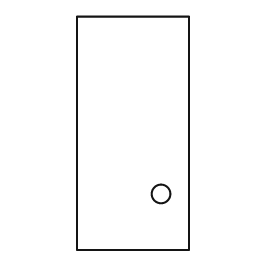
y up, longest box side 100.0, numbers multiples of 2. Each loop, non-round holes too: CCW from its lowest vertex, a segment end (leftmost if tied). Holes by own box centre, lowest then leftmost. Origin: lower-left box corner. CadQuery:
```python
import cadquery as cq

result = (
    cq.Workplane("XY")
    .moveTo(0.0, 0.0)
    .lineTo(48.0, 0.0)
    .lineTo(48.0, 100.0)
    .lineTo(0.0, 100.0)
    .close()
    .moveTo(36.0, 24.0)
    .circle(4.0)
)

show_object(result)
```